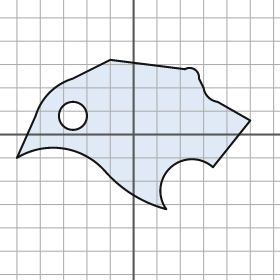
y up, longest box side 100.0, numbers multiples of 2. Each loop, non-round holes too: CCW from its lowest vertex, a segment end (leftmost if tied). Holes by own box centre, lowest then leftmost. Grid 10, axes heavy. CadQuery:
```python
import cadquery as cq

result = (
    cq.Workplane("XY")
    .moveTo(14.0, -32.0)
    .threePointArc((16.0, -14.0), (34.0, -14.0))
    .lineTo(50.0, 6.0)
    .lineTo(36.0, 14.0)
    .threePointArc((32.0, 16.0), (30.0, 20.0))
    .lineTo(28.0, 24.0)
    .threePointArc((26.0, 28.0), (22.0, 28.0))
    .lineTo(-10.0, 32.0)
    .lineTo(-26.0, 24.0)
    .threePointArc((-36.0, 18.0), (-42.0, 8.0))
    .lineTo(-50.0, -10.0)
    .threePointArc((-30.0, -6.0), (-12.0, -16.0))
    .threePointArc((0.0, -26.0), (14.0, -32.0))
    .close()
    .moveTo(-26.0, 8.0)
    .circle(6.0)
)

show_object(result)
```